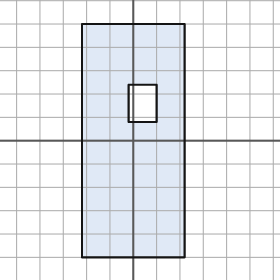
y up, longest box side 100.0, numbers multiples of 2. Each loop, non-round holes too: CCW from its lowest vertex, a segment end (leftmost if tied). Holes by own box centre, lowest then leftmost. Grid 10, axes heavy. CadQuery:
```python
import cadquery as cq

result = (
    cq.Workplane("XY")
    .moveTo(-22.0, -50.0)
    .lineTo(22.0, -50.0)
    .lineTo(22.0, 50.0)
    .lineTo(-22.0, 50.0)
    .close()
    .moveTo(-2.0, 8.0)
    .lineTo(10.0, 8.0)
    .lineTo(10.0, 24.0)
    .lineTo(-2.0, 24.0)
    .close()
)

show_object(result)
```